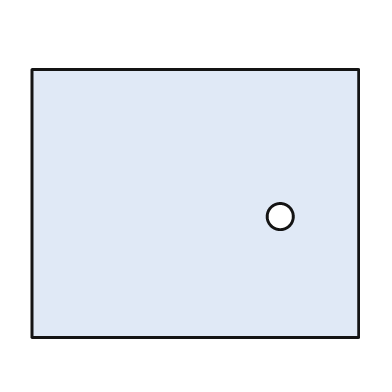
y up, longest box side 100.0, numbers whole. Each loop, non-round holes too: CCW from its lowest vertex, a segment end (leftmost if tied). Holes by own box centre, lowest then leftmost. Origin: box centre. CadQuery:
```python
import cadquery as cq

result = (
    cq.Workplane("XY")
    .moveTo(-50.0, -41.0)
    .lineTo(50.0, -41.0)
    .lineTo(50.0, 41.0)
    .lineTo(-50.0, 41.0)
    .close()
    .moveTo(26.0, -4.0)
    .circle(4.0)
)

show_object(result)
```